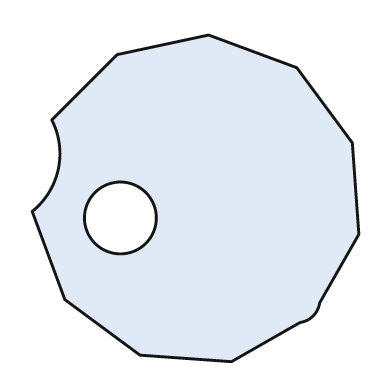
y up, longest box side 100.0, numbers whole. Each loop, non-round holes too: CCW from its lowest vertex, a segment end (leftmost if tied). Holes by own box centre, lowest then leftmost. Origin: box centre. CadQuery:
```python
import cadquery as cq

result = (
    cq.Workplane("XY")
    .moveTo(11.0, -50.0)
    .lineTo(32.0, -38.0)
    .threePointArc((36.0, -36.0), (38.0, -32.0))
    .lineTo(50.0, -11.0)
    .lineTo(48.0, 17.0)
    .lineTo(31.0, 40.0)
    .lineTo(4.0, 50.0)
    .lineTo(-24.0, 44.0)
    .lineTo(-44.0, 24.0)
    .threePointArc((-42.0, 9.0), (-50.0, -4.0))
    .lineTo(-40.0, -31.0)
    .lineTo(-17.0, -48.0)
    .close()
    .moveTo(-23.0, -6.0)
    .circle(11.0)
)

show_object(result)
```